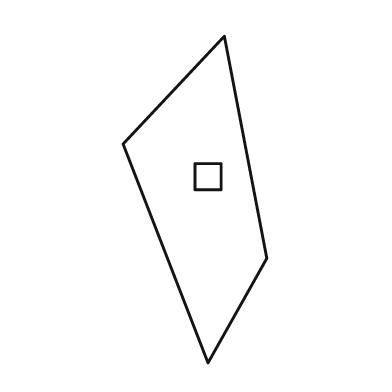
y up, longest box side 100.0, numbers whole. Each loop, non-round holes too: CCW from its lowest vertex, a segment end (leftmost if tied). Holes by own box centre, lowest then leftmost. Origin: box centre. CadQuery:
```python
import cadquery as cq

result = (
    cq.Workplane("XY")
    .moveTo(4.0, -50.0)
    .lineTo(22.0, -18.0)
    .lineTo(9.0, 50.0)
    .lineTo(-22.0, 17.0)
    .close()
    .moveTo(0.0, 3.0)
    .lineTo(8.0, 3.0)
    .lineTo(8.0, 11.0)
    .lineTo(0.0, 11.0)
    .close()
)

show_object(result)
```